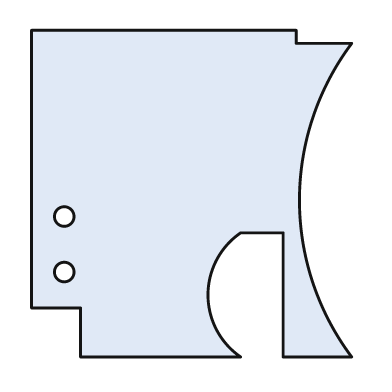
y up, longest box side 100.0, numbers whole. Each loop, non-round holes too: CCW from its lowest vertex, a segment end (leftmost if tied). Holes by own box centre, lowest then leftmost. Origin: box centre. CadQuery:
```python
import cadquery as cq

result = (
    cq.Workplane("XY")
    .moveTo(-34.0, -50.0)
    .lineTo(15.0, -50.0)
    .threePointArc((5.0, -31.0), (15.0, -12.0))
    .lineTo(28.0, -12.0)
    .lineTo(28.0, -50.0)
    .lineTo(49.0, -50.0)
    .threePointArc((33.0, -2.0), (49.0, 46.0))
    .lineTo(32.0, 46.0)
    .lineTo(32.0, 50.0)
    .lineTo(-49.0, 50.0)
    .lineTo(-49.0, -35.0)
    .lineTo(-34.0, -35.0)
    .close()
    .moveTo(-39.0, -24.0)
    .circle(3.0)
    .moveTo(-39.0, -7.0)
    .circle(3.0)
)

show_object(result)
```